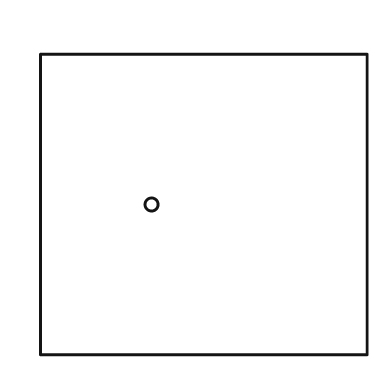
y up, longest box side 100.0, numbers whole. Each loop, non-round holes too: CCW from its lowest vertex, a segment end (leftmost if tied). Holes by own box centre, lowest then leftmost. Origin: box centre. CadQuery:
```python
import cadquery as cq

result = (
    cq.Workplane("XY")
    .moveTo(-50.0, -46.0)
    .lineTo(50.0, -46.0)
    .lineTo(50.0, 46.0)
    .lineTo(-50.0, 46.0)
    .close()
    .moveTo(-16.0, 0.0)
    .circle(2.0)
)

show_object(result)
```